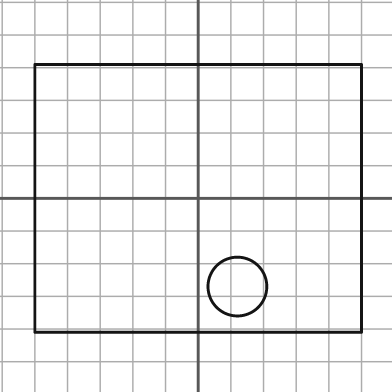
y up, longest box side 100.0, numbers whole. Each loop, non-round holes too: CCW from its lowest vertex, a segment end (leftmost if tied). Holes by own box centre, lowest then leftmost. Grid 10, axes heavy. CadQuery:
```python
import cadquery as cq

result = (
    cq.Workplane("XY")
    .moveTo(-50.0, -41.0)
    .lineTo(50.0, -41.0)
    .lineTo(50.0, 41.0)
    .lineTo(-50.0, 41.0)
    .close()
    .moveTo(12.0, -27.0)
    .circle(9.0)
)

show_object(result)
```